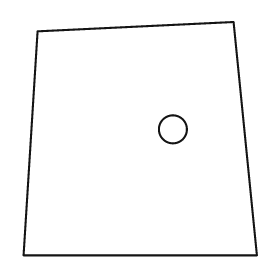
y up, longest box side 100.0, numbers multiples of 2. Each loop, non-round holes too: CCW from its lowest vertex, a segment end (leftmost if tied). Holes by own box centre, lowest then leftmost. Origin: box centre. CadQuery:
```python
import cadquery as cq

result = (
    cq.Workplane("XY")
    .moveTo(-50.0, -50.0)
    .lineTo(50.0, -50.0)
    .lineTo(40.0, 50.0)
    .lineTo(-44.0, 46.0)
    .close()
    .moveTo(14.0, 4.0)
    .circle(6.0)
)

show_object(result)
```